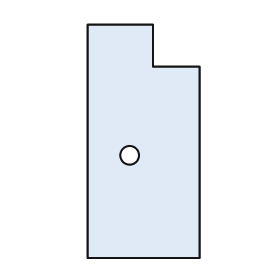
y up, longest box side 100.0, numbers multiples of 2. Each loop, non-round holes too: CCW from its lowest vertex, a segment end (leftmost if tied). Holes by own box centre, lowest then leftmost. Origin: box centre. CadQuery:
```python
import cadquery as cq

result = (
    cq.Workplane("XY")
    .moveTo(-24.0, -50.0)
    .lineTo(24.0, -50.0)
    .lineTo(24.0, 32.0)
    .lineTo(4.0, 32.0)
    .lineTo(4.0, 50.0)
    .lineTo(-24.0, 50.0)
    .close()
    .moveTo(-6.0, -6.0)
    .circle(4.0)
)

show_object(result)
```